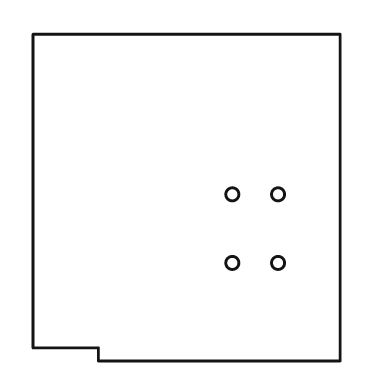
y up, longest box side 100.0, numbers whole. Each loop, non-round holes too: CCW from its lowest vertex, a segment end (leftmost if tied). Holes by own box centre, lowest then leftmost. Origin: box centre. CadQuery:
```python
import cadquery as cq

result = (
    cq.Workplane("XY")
    .moveTo(-27.0, -50.0)
    .lineTo(47.0, -50.0)
    .lineTo(47.0, 50.0)
    .lineTo(-47.0, 50.0)
    .lineTo(-47.0, -46.0)
    .lineTo(-27.0, -46.0)
    .close()
    .moveTo(14.0, -20.0)
    .circle(2.0)
    .moveTo(28.0, -20.0)
    .circle(2.0)
    .moveTo(14.0, 1.0)
    .circle(2.0)
    .moveTo(28.0, 1.0)
    .circle(2.0)
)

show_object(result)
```